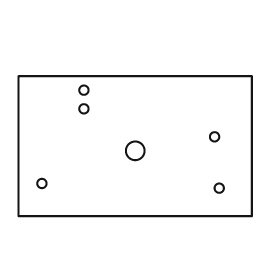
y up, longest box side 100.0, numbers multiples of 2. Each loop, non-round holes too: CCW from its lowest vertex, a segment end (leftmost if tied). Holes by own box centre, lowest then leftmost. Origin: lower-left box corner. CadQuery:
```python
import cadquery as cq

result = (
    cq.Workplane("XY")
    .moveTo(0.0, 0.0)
    .lineTo(100.0, 0.0)
    .lineTo(100.0, 60.0)
    .lineTo(0.0, 60.0)
    .close()
    .moveTo(86.0, 12.0)
    .circle(2.0)
    .moveTo(10.0, 14.0)
    .circle(2.0)
    .moveTo(50.0, 28.0)
    .circle(4.0)
    .moveTo(84.0, 34.0)
    .circle(2.0)
    .moveTo(28.0, 46.0)
    .circle(2.0)
    .moveTo(28.0, 54.0)
    .circle(2.0)
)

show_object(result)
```